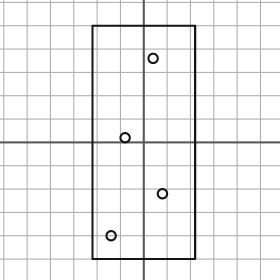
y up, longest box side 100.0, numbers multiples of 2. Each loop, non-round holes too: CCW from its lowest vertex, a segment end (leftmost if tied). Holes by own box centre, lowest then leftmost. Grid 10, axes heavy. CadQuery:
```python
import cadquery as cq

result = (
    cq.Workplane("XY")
    .moveTo(-22.0, -50.0)
    .lineTo(22.0, -50.0)
    .lineTo(22.0, 50.0)
    .lineTo(-22.0, 50.0)
    .close()
    .moveTo(-14.0, -40.0)
    .circle(2.0)
    .moveTo(8.0, -22.0)
    .circle(2.0)
    .moveTo(-8.0, 2.0)
    .circle(2.0)
    .moveTo(4.0, 36.0)
    .circle(2.0)
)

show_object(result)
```